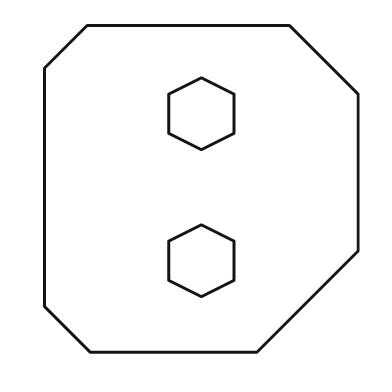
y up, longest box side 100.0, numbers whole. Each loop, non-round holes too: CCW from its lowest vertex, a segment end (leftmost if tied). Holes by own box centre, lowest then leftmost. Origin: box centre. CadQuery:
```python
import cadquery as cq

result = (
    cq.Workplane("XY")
    .moveTo(-34.0, -50.0)
    .lineTo(17.0, -50.0)
    .lineTo(48.0, -19.0)
    .lineTo(48.0, 29.0)
    .lineTo(27.0, 50.0)
    .lineTo(-35.0, 50.0)
    .lineTo(-48.0, 37.0)
    .lineTo(-48.0, -36.0)
    .close()
    .moveTo(0.0, -33.0)
    .lineTo(10.0, -28.0)
    .lineTo(10.0, -16.0)
    .lineTo(0.0, -11.0)
    .lineTo(-10.0, -16.0)
    .lineTo(-10.0, -28.0)
    .close()
    .moveTo(0.0, 12.0)
    .lineTo(10.0, 17.0)
    .lineTo(10.0, 29.0)
    .lineTo(0.0, 34.0)
    .lineTo(-10.0, 29.0)
    .lineTo(-10.0, 17.0)
    .close()
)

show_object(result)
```